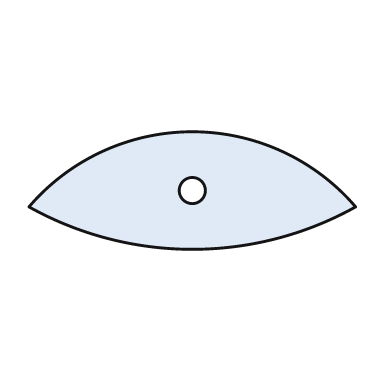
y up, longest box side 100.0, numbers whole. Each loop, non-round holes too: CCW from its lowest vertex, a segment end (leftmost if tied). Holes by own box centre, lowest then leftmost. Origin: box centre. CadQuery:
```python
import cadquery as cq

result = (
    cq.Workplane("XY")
    .moveTo(-50.0, -5.0)
    .threePointArc((0.0, -18.0), (50.0, -5.0))
    .threePointArc((0.0, 18.0), (-50.0, -5.0))
    .close()
    .moveTo(0.0, 0.0)
    .circle(4.0)
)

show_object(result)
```